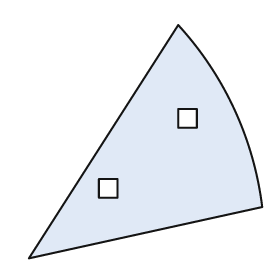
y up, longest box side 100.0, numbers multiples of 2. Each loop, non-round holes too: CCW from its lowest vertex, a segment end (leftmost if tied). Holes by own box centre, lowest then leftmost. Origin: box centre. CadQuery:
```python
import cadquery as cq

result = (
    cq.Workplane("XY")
    .moveTo(-50.0, -50.0)
    .lineTo(50.0, -28.0)
    .threePointArc((38.0, 14.0), (14.0, 50.0))
    .close()
    .moveTo(-20.0, -24.0)
    .lineTo(-12.0, -24.0)
    .lineTo(-12.0, -16.0)
    .lineTo(-20.0, -16.0)
    .close()
    .moveTo(14.0, 6.0)
    .lineTo(22.0, 6.0)
    .lineTo(22.0, 14.0)
    .lineTo(14.0, 14.0)
    .close()
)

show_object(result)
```